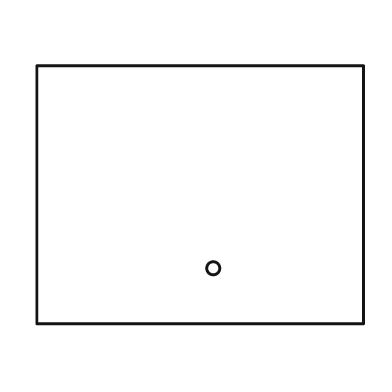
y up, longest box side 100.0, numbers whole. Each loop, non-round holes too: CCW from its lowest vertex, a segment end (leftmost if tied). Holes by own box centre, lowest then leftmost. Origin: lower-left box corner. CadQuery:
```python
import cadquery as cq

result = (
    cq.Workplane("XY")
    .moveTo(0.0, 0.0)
    .lineTo(100.0, 0.0)
    .lineTo(100.0, 79.0)
    .lineTo(0.0, 79.0)
    .close()
    .moveTo(54.0, 17.0)
    .circle(2.0)
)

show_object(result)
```